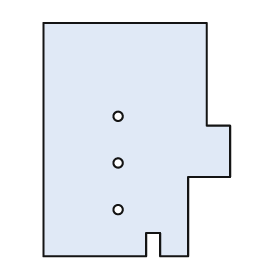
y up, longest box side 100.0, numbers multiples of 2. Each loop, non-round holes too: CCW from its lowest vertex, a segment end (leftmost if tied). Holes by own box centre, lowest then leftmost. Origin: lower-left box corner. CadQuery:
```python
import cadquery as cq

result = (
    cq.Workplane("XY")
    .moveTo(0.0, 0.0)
    .lineTo(44.0, 0.0)
    .lineTo(44.0, 10.0)
    .lineTo(50.0, 10.0)
    .lineTo(50.0, 0.0)
    .lineTo(62.0, 0.0)
    .lineTo(62.0, 34.0)
    .lineTo(80.0, 34.0)
    .lineTo(80.0, 56.0)
    .lineTo(70.0, 56.0)
    .lineTo(70.0, 100.0)
    .lineTo(0.0, 100.0)
    .close()
    .moveTo(32.0, 20.0)
    .circle(2.0)
    .moveTo(32.0, 40.0)
    .circle(2.0)
    .moveTo(32.0, 60.0)
    .circle(2.0)
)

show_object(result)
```